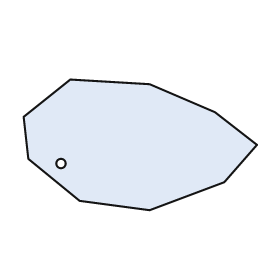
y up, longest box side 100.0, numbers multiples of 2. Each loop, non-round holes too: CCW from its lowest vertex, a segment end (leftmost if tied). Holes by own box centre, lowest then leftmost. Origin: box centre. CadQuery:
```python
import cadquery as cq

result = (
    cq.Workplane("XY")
    .moveTo(4.0, -28.0)
    .lineTo(36.0, -16.0)
    .lineTo(50.0, 0.0)
    .lineTo(32.0, 14.0)
    .lineTo(4.0, 26.0)
    .lineTo(-30.0, 28.0)
    .lineTo(-50.0, 12.0)
    .lineTo(-48.0, -6.0)
    .lineTo(-26.0, -24.0)
    .close()
    .moveTo(-34.0, -8.0)
    .circle(2.0)
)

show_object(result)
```